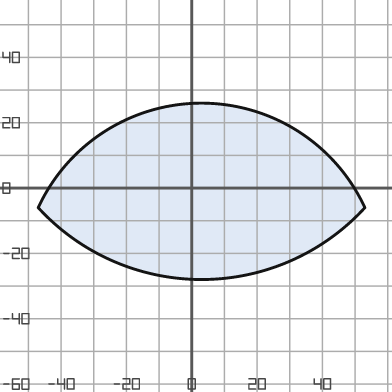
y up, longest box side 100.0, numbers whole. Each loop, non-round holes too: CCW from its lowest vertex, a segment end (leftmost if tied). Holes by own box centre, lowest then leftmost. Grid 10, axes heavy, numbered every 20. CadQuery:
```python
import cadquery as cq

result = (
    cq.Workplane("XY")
    .moveTo(-47.0, -6.0)
    .threePointArc((3.0, -28.0), (53.0, -6.0))
    .threePointArc((3.0, 26.0), (-47.0, -6.0))
    .close()
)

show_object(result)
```